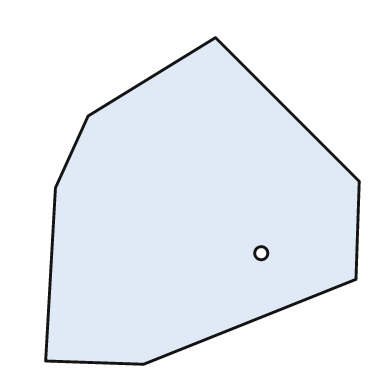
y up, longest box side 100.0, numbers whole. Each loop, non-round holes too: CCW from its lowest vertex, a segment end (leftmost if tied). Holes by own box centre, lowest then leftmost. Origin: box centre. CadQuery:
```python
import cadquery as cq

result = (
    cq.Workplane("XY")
    .moveTo(-18.0, -50.0)
    .lineTo(47.0, -24.0)
    .lineTo(48.0, 6.0)
    .lineTo(4.0, 50.0)
    .lineTo(-35.0, 26.0)
    .lineTo(-45.0, 4.0)
    .lineTo(-48.0, -49.0)
    .close()
    .moveTo(18.0, -16.0)
    .circle(2.0)
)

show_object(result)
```